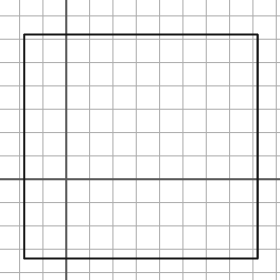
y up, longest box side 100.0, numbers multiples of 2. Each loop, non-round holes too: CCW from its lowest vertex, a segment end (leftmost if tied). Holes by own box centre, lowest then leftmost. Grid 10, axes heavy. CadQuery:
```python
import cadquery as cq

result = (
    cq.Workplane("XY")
    .moveTo(-18.0, -34.0)
    .lineTo(82.0, -34.0)
    .lineTo(82.0, 62.0)
    .lineTo(-18.0, 62.0)
    .close()
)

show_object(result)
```